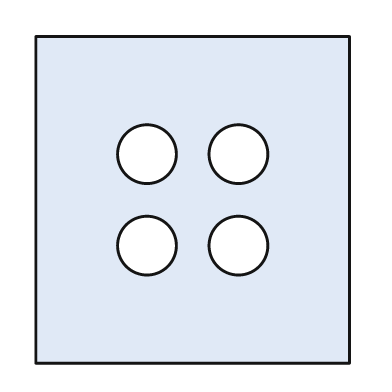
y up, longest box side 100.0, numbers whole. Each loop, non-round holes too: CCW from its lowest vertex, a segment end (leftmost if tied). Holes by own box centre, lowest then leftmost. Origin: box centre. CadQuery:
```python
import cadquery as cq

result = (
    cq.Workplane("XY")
    .moveTo(-48.0, -50.0)
    .lineTo(48.0, -50.0)
    .lineTo(48.0, 50.0)
    .lineTo(-48.0, 50.0)
    .close()
    .moveTo(-14.0, -14.0)
    .circle(9.0)
    .moveTo(14.0, -14.0)
    .circle(9.0)
    .moveTo(-14.0, 14.0)
    .circle(9.0)
    .moveTo(14.0, 14.0)
    .circle(9.0)
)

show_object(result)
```